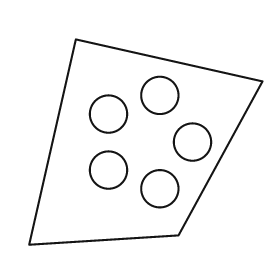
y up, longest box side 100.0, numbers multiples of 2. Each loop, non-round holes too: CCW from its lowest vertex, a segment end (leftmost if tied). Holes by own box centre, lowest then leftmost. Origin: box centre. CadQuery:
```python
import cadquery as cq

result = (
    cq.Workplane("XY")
    .moveTo(-50.0, -44.0)
    .lineTo(14.0, -40.0)
    .lineTo(50.0, 26.0)
    .lineTo(-30.0, 44.0)
    .close()
    .moveTo(6.0, -20.0)
    .circle(8.0)
    .moveTo(-16.0, -12.0)
    .circle(8.0)
    .moveTo(20.0, 0.0)
    .circle(8.0)
    .moveTo(-16.0, 12.0)
    .circle(8.0)
    .moveTo(6.0, 20.0)
    .circle(8.0)
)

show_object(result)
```